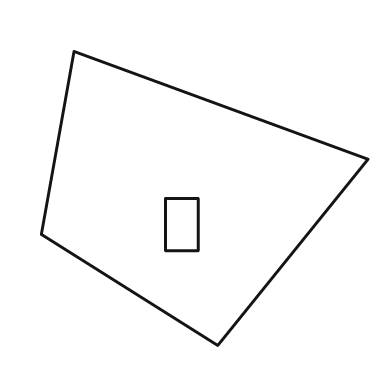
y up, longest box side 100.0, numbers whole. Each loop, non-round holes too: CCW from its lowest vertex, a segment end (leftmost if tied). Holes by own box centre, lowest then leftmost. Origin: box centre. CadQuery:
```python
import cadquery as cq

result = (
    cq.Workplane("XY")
    .moveTo(4.0, -45.0)
    .lineTo(50.0, 12.0)
    .lineTo(-40.0, 45.0)
    .lineTo(-50.0, -11.0)
    .close()
    .moveTo(-12.0, -16.0)
    .lineTo(-2.0, -16.0)
    .lineTo(-2.0, 0.0)
    .lineTo(-12.0, 0.0)
    .close()
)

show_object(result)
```